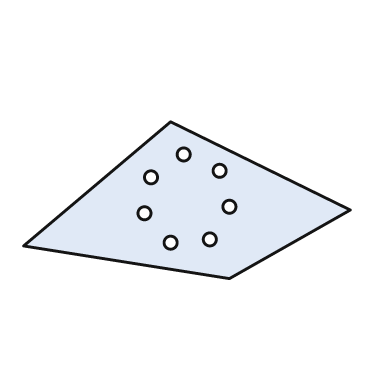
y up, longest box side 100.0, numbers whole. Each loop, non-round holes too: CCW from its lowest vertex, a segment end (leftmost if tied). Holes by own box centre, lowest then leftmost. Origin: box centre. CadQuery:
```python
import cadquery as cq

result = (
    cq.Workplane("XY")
    .moveTo(13.0, -24.0)
    .lineTo(50.0, -3.0)
    .lineTo(-5.0, 24.0)
    .lineTo(-50.0, -14.0)
    .close()
    .moveTo(-5.0, -13.0)
    .circle(2.0)
    .moveTo(7.0, -12.0)
    .circle(2.0)
    .moveTo(-13.0, -4.0)
    .circle(2.0)
    .moveTo(13.0, -2.0)
    .circle(2.0)
    .moveTo(-11.0, 7.0)
    .circle(2.0)
    .moveTo(10.0, 9.0)
    .circle(2.0)
    .moveTo(-1.0, 14.0)
    .circle(2.0)
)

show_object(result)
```